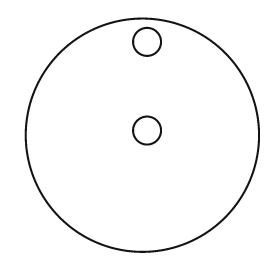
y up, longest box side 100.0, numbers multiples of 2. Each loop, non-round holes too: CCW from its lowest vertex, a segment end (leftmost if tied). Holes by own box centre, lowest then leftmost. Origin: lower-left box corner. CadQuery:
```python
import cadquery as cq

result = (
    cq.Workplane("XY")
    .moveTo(50.0, 50.0)
    .circle(50.0)
    .moveTo(52.0, 52.0)
    .circle(6.0)
    .moveTo(52.0, 90.0)
    .circle(6.0)
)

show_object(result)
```